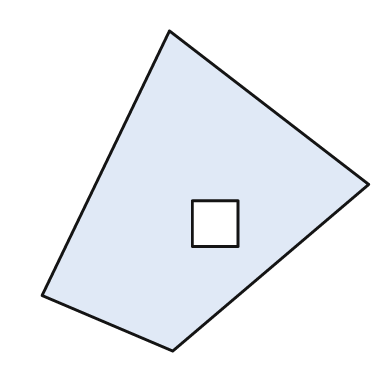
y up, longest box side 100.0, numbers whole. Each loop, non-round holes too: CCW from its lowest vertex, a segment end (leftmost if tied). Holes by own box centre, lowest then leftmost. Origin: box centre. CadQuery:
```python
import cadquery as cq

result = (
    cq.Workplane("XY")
    .moveTo(-10.0, -49.0)
    .lineTo(50.0, 2.0)
    .lineTo(-11.0, 49.0)
    .lineTo(-50.0, -32.0)
    .close()
    .moveTo(-4.0, -17.0)
    .lineTo(10.0, -17.0)
    .lineTo(10.0, -3.0)
    .lineTo(-4.0, -3.0)
    .close()
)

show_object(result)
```